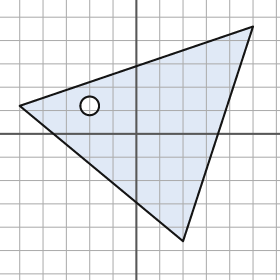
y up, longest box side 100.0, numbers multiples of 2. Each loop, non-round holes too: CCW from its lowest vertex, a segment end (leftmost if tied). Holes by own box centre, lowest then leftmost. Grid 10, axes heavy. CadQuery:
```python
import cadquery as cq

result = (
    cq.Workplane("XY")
    .moveTo(20.0, -46.0)
    .lineTo(50.0, 46.0)
    .lineTo(-50.0, 12.0)
    .close()
    .moveTo(-20.0, 12.0)
    .circle(4.0)
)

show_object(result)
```